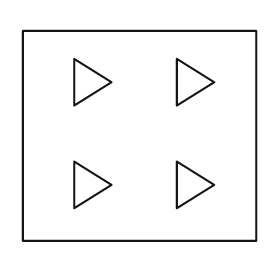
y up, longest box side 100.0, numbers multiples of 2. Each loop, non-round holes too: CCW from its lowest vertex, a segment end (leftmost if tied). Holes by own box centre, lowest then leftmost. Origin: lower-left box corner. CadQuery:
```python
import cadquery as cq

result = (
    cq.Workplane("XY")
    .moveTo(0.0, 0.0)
    .lineTo(100.0, 0.0)
    .lineTo(100.0, 90.0)
    .lineTo(0.0, 90.0)
    .close()
    .moveTo(22.0, 14.0)
    .lineTo(38.0, 24.0)
    .lineTo(22.0, 34.0)
    .close()
    .moveTo(66.0, 14.0)
    .lineTo(82.0, 24.0)
    .lineTo(66.0, 34.0)
    .close()
    .moveTo(22.0, 58.0)
    .lineTo(38.0, 68.0)
    .lineTo(22.0, 78.0)
    .close()
    .moveTo(66.0, 58.0)
    .lineTo(82.0, 68.0)
    .lineTo(66.0, 78.0)
    .close()
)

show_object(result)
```